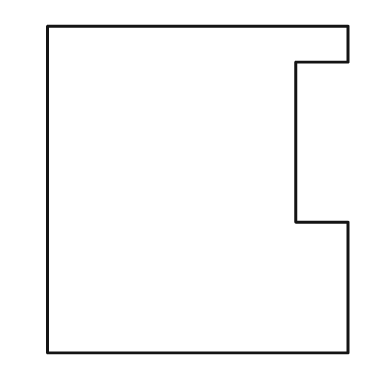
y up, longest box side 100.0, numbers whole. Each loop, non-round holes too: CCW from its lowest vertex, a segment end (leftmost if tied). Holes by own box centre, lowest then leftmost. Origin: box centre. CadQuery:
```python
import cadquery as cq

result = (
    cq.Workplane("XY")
    .moveTo(-46.0, -50.0)
    .lineTo(46.0, -50.0)
    .lineTo(46.0, -10.0)
    .lineTo(30.0, -10.0)
    .lineTo(30.0, 39.0)
    .lineTo(46.0, 39.0)
    .lineTo(46.0, 50.0)
    .lineTo(-46.0, 50.0)
    .close()
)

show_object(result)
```